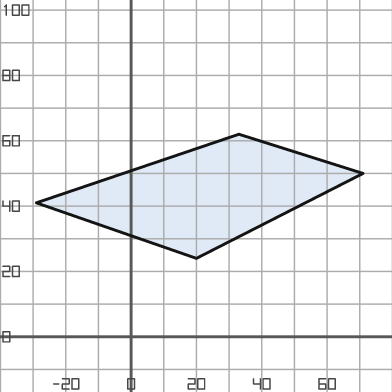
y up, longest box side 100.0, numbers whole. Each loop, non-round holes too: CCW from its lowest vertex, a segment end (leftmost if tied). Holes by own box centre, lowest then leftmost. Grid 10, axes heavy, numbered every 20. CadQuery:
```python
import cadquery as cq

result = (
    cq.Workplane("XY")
    .moveTo(20.0, 24.0)
    .lineTo(71.0, 50.0)
    .lineTo(33.0, 62.0)
    .lineTo(-29.0, 41.0)
    .close()
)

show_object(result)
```